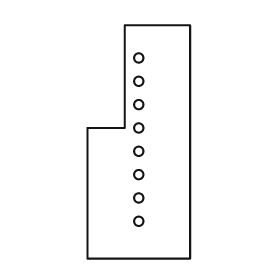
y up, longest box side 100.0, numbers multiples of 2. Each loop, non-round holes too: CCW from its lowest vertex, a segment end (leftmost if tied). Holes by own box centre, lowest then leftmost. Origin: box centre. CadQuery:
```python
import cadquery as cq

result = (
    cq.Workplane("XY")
    .moveTo(-22.0, -50.0)
    .lineTo(22.0, -50.0)
    .lineTo(22.0, 50.0)
    .lineTo(-6.0, 50.0)
    .lineTo(-6.0, 6.0)
    .lineTo(-22.0, 6.0)
    .close()
    .moveTo(0.0, -34.0)
    .circle(2.0)
    .moveTo(0.0, -24.0)
    .circle(2.0)
    .moveTo(0.0, -14.0)
    .circle(2.0)
    .moveTo(0.0, -4.0)
    .circle(2.0)
    .moveTo(0.0, 6.0)
    .circle(2.0)
    .moveTo(0.0, 16.0)
    .circle(2.0)
    .moveTo(0.0, 26.0)
    .circle(2.0)
    .moveTo(0.0, 36.0)
    .circle(2.0)
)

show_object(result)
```